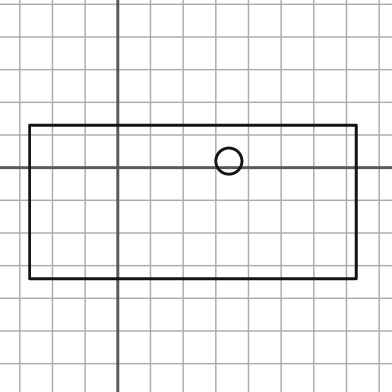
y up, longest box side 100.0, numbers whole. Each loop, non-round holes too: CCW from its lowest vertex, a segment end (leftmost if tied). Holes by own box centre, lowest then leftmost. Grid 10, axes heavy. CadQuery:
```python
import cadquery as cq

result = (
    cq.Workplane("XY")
    .moveTo(-27.0, -34.0)
    .lineTo(73.0, -34.0)
    .lineTo(73.0, 13.0)
    .lineTo(-27.0, 13.0)
    .close()
    .moveTo(34.0, 2.0)
    .circle(4.0)
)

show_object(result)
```